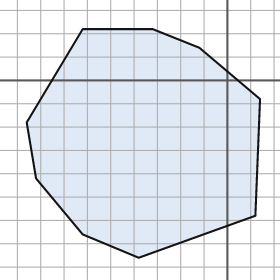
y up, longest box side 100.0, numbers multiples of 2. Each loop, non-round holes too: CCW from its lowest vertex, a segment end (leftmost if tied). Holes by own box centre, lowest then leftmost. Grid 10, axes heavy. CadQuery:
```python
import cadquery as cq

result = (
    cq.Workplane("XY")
    .moveTo(-38.0, -76.0)
    .lineTo(12.0, -58.0)
    .lineTo(14.0, -8.0)
    .lineTo(-12.0, 14.0)
    .lineTo(-32.0, 22.0)
    .lineTo(-62.0, 22.0)
    .lineTo(-86.0, -18.0)
    .lineTo(-82.0, -42.0)
    .lineTo(-62.0, -66.0)
    .close()
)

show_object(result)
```